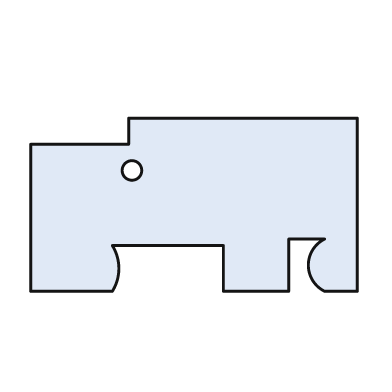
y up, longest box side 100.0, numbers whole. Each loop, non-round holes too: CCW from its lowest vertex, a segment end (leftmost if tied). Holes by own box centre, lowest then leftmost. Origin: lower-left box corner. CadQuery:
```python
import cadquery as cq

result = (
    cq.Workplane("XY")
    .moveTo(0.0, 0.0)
    .lineTo(25.0, 0.0)
    .threePointArc((27.0, 7.0), (25.0, 14.0))
    .lineTo(59.0, 14.0)
    .lineTo(59.0, 0.0)
    .lineTo(79.0, 0.0)
    .lineTo(79.0, 16.0)
    .lineTo(90.0, 16.0)
    .threePointArc((85.0, 8.0), (90.0, 0.0))
    .lineTo(100.0, 0.0)
    .lineTo(100.0, 53.0)
    .lineTo(30.0, 53.0)
    .lineTo(30.0, 45.0)
    .lineTo(0.0, 45.0)
    .close()
    .moveTo(31.0, 37.0)
    .circle(3.0)
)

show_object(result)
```